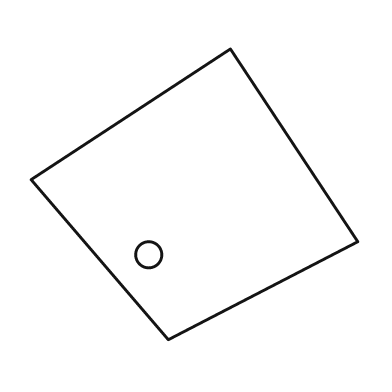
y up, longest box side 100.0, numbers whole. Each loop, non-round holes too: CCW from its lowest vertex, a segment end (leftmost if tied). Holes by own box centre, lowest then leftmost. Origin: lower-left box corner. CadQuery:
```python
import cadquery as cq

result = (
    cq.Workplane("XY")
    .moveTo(42.0, 0.0)
    .lineTo(100.0, 30.0)
    .lineTo(61.0, 89.0)
    .lineTo(0.0, 49.0)
    .close()
    .moveTo(36.0, 26.0)
    .circle(4.0)
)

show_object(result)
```